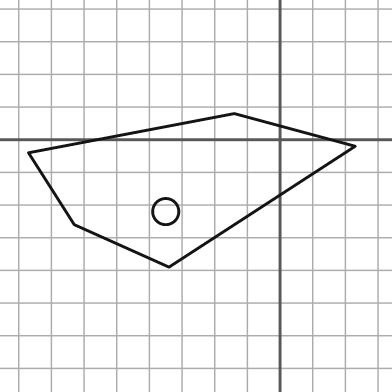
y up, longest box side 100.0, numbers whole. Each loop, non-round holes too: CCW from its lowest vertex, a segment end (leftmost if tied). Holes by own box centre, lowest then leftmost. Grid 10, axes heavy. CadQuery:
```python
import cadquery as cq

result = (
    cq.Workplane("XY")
    .moveTo(-34.0, -39.0)
    .lineTo(23.0, -2.0)
    .lineTo(-14.0, 8.0)
    .lineTo(-77.0, -4.0)
    .lineTo(-63.0, -26.0)
    .close()
    .moveTo(-35.0, -22.0)
    .circle(4.0)
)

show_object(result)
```